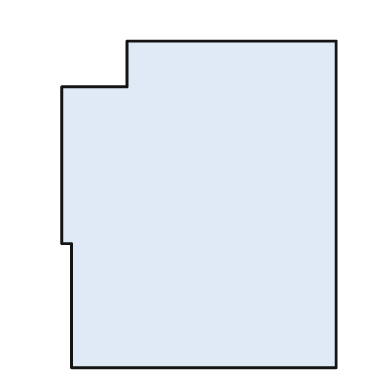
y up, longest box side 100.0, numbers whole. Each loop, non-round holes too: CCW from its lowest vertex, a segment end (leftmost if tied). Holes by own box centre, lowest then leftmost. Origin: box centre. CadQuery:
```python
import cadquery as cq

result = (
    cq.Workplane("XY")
    .moveTo(-39.0, -50.0)
    .lineTo(42.0, -50.0)
    .lineTo(42.0, 50.0)
    .lineTo(-22.0, 50.0)
    .lineTo(-22.0, 36.0)
    .lineTo(-42.0, 36.0)
    .lineTo(-42.0, -12.0)
    .lineTo(-39.0, -12.0)
    .close()
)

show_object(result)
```